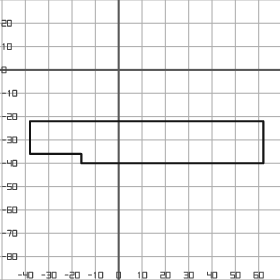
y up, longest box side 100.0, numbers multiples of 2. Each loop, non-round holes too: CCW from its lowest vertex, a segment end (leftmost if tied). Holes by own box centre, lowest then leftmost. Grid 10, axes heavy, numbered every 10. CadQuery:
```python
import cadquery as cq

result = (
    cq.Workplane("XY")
    .moveTo(-16.0, -40.0)
    .lineTo(62.0, -40.0)
    .lineTo(62.0, -22.0)
    .lineTo(-38.0, -22.0)
    .lineTo(-38.0, -36.0)
    .lineTo(-16.0, -36.0)
    .close()
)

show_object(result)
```